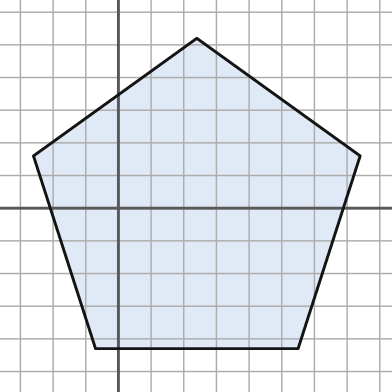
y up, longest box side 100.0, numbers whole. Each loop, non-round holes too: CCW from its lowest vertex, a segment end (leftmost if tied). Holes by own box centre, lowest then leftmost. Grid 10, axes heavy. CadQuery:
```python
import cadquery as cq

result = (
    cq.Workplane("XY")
    .moveTo(-7.0, -43.0)
    .lineTo(55.0, -43.0)
    .lineTo(74.0, 16.0)
    .lineTo(24.0, 52.0)
    .lineTo(-26.0, 16.0)
    .close()
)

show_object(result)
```